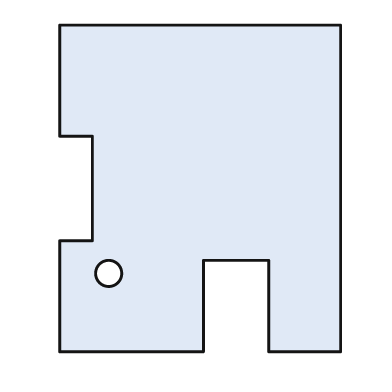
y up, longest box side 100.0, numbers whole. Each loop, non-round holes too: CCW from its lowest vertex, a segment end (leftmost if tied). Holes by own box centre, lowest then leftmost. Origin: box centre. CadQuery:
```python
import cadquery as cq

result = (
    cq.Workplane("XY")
    .moveTo(-43.0, -50.0)
    .lineTo(1.0, -50.0)
    .lineTo(1.0, -22.0)
    .lineTo(21.0, -22.0)
    .lineTo(21.0, -50.0)
    .lineTo(43.0, -50.0)
    .lineTo(43.0, 50.0)
    .lineTo(-43.0, 50.0)
    .lineTo(-43.0, 16.0)
    .lineTo(-33.0, 16.0)
    .lineTo(-33.0, -16.0)
    .lineTo(-43.0, -16.0)
    .close()
    .moveTo(-28.0, -26.0)
    .circle(4.0)
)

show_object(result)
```